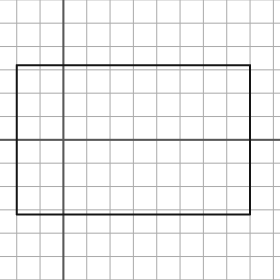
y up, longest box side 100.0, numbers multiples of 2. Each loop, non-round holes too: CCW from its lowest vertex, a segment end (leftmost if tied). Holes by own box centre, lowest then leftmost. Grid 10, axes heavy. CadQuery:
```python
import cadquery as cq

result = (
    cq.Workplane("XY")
    .moveTo(-20.0, -32.0)
    .lineTo(80.0, -32.0)
    .lineTo(80.0, 32.0)
    .lineTo(-20.0, 32.0)
    .close()
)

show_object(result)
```